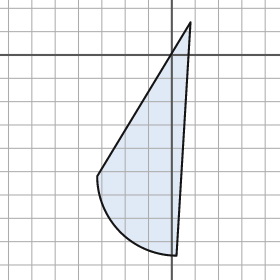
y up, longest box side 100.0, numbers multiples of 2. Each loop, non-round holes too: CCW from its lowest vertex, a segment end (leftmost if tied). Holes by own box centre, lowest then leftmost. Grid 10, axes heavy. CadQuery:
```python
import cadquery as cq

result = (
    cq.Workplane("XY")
    .moveTo(2.0, -86.0)
    .lineTo(8.0, 14.0)
    .lineTo(-32.0, -52.0)
    .threePointArc((-22.0, -76.0), (2.0, -86.0))
    .close()
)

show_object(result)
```